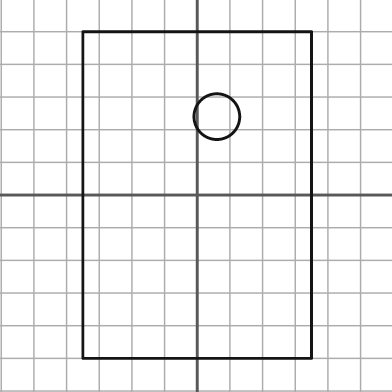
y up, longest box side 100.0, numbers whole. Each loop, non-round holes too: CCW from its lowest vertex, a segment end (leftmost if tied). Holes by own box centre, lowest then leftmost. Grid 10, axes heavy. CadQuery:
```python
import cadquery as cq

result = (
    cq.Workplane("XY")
    .moveTo(-35.0, -50.0)
    .lineTo(35.0, -50.0)
    .lineTo(35.0, 50.0)
    .lineTo(-35.0, 50.0)
    .close()
    .moveTo(6.0, 24.0)
    .circle(7.0)
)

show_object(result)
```